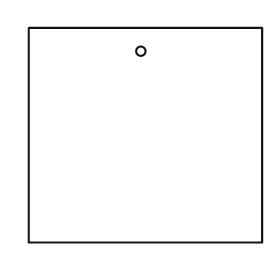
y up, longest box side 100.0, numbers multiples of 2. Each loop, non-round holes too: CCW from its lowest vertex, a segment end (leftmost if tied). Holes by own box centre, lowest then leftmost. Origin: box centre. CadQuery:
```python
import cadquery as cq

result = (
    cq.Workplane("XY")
    .moveTo(-50.0, -46.0)
    .lineTo(50.0, -46.0)
    .lineTo(50.0, 46.0)
    .lineTo(-50.0, 46.0)
    .close()
    .moveTo(-2.0, 36.0)
    .circle(2.0)
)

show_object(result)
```